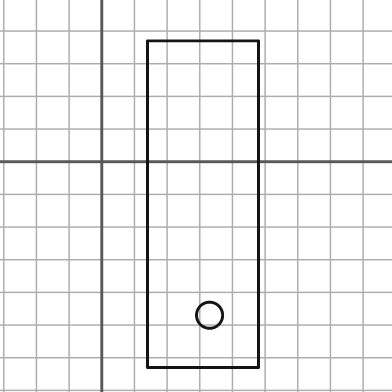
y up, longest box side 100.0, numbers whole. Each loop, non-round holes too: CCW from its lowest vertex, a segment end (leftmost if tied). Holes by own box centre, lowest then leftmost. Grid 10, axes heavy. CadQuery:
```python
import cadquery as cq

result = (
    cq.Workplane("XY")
    .moveTo(14.0, -63.0)
    .lineTo(48.0, -63.0)
    .lineTo(48.0, 37.0)
    .lineTo(14.0, 37.0)
    .close()
    .moveTo(33.0, -47.0)
    .circle(4.0)
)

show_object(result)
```